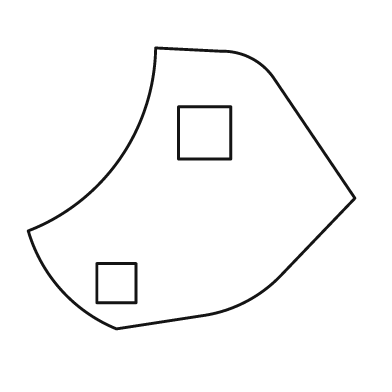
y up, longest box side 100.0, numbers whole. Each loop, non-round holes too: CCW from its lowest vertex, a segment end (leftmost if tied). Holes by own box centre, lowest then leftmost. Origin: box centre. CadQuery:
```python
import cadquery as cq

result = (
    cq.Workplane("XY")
    .moveTo(-23.0, -43.0)
    .lineTo(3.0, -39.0)
    .threePointArc((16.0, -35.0), (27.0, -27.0))
    .lineTo(50.0, -3.0)
    .lineTo(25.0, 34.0)
    .threePointArc((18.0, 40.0), (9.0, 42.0))
    .lineTo(-11.0, 43.0)
    .threePointArc((-22.0, 9.0), (-50.0, -13.0))
    .threePointArc((-40.0, -31.0), (-23.0, -43.0))
    .close()
    .moveTo(-29.0, -35.0)
    .lineTo(-17.0, -35.0)
    .lineTo(-17.0, -23.0)
    .lineTo(-29.0, -23.0)
    .close()
    .moveTo(-4.0, 9.0)
    .lineTo(12.0, 9.0)
    .lineTo(12.0, 25.0)
    .lineTo(-4.0, 25.0)
    .close()
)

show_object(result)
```